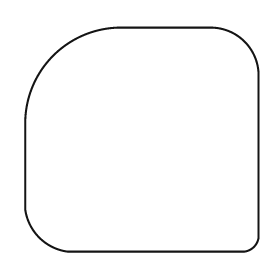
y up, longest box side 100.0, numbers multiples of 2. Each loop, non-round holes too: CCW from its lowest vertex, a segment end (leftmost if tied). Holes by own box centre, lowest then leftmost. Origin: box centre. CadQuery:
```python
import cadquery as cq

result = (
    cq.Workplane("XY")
    .moveTo(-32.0, -48.0)
    .lineTo(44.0, -48.0)
    .threePointArc((48.0, -46.0), (50.0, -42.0))
    .lineTo(50.0, 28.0)
    .threePointArc((44.0, 42.0), (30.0, 48.0))
    .lineTo(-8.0, 48.0)
    .threePointArc((-38.0, 36.0), (-50.0, 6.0))
    .lineTo(-50.0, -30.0)
    .threePointArc((-44.0, -42.0), (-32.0, -48.0))
    .close()
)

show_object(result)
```